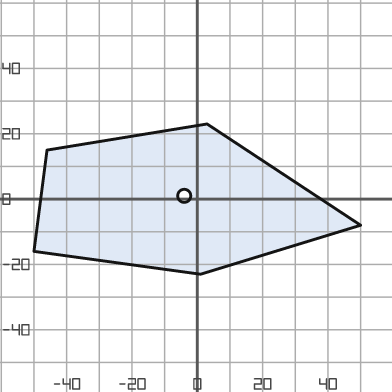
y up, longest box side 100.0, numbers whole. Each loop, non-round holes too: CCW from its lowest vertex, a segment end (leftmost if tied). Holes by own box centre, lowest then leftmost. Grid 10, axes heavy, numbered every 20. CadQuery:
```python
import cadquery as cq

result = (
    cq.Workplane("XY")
    .moveTo(1.0, -23.0)
    .lineTo(50.0, -8.0)
    .lineTo(3.0, 23.0)
    .lineTo(-46.0, 15.0)
    .lineTo(-50.0, -16.0)
    .close()
    .moveTo(-4.0, 1.0)
    .circle(2.0)
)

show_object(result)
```